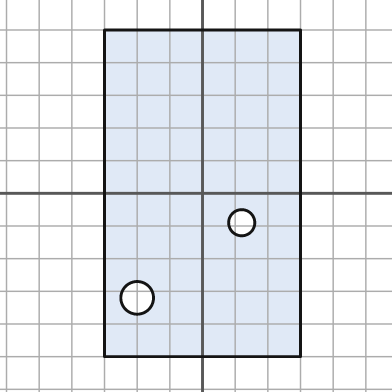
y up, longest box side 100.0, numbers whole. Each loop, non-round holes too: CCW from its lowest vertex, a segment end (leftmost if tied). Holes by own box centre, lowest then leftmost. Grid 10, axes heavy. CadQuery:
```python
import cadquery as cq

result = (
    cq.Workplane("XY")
    .moveTo(-30.0, -50.0)
    .lineTo(30.0, -50.0)
    .lineTo(30.0, 50.0)
    .lineTo(-30.0, 50.0)
    .close()
    .moveTo(-20.0, -32.0)
    .circle(5.0)
    .moveTo(12.0, -9.0)
    .circle(4.0)
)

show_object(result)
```